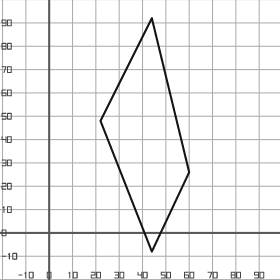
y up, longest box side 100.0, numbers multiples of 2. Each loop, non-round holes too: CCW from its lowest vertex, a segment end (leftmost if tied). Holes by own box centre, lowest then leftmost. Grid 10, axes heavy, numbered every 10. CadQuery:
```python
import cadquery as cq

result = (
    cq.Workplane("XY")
    .moveTo(44.0, -8.0)
    .lineTo(60.0, 26.0)
    .lineTo(44.0, 92.0)
    .lineTo(22.0, 48.0)
    .close()
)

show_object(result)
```